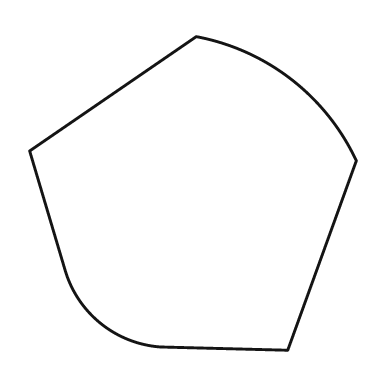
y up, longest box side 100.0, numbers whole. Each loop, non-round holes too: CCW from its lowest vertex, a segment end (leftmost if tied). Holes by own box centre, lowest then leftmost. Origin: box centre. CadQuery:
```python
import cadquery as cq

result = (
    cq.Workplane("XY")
    .moveTo(29.0, -48.0)
    .lineTo(50.0, 10.0)
    .threePointArc((30.0, 35.0), (1.0, 48.0))
    .lineTo(-50.0, 13.0)
    .lineTo(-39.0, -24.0)
    .threePointArc((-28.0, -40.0), (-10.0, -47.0))
    .close()
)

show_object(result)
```